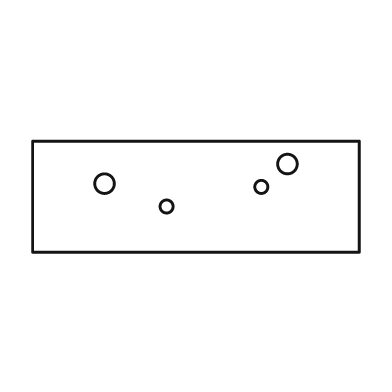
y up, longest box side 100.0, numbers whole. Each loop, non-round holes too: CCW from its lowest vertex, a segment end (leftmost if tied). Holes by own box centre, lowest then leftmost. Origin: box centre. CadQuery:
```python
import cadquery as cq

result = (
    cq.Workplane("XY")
    .moveTo(-50.0, -17.0)
    .lineTo(50.0, -17.0)
    .lineTo(50.0, 17.0)
    .lineTo(-50.0, 17.0)
    .close()
    .moveTo(-9.0, -3.0)
    .circle(2.0)
    .moveTo(20.0, 3.0)
    .circle(2.0)
    .moveTo(-28.0, 4.0)
    .circle(3.0)
    .moveTo(28.0, 10.0)
    .circle(3.0)
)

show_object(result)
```